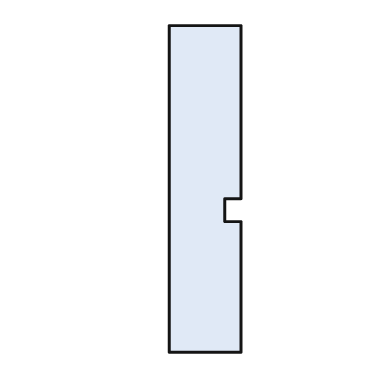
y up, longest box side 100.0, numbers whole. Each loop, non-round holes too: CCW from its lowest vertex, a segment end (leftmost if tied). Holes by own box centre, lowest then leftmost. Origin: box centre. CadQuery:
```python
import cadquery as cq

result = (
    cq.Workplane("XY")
    .moveTo(-11.0, -50.0)
    .lineTo(11.0, -50.0)
    .lineTo(11.0, -10.0)
    .lineTo(6.0, -10.0)
    .lineTo(6.0, -3.0)
    .lineTo(11.0, -3.0)
    .lineTo(11.0, 50.0)
    .lineTo(-11.0, 50.0)
    .close()
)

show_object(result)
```